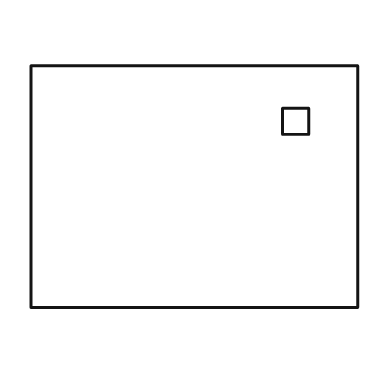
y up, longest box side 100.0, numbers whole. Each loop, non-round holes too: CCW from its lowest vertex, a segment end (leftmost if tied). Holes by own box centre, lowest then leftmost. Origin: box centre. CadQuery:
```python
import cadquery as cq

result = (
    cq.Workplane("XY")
    .moveTo(-50.0, -37.0)
    .lineTo(50.0, -37.0)
    .lineTo(50.0, 37.0)
    .lineTo(-50.0, 37.0)
    .close()
    .moveTo(27.0, 16.0)
    .lineTo(35.0, 16.0)
    .lineTo(35.0, 24.0)
    .lineTo(27.0, 24.0)
    .close()
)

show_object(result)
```